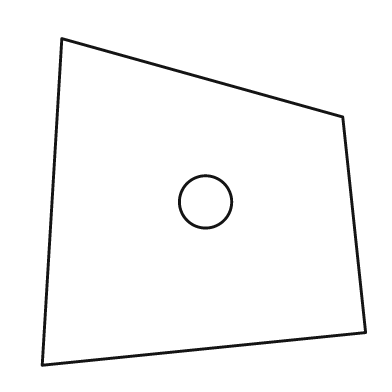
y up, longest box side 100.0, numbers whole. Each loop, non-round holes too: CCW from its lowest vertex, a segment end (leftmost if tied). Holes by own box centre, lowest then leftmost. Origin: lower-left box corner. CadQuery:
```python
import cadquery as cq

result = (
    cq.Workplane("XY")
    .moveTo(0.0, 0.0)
    .lineTo(99.0, 10.0)
    .lineTo(92.0, 76.0)
    .lineTo(6.0, 100.0)
    .close()
    .moveTo(50.0, 50.0)
    .circle(8.0)
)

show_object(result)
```